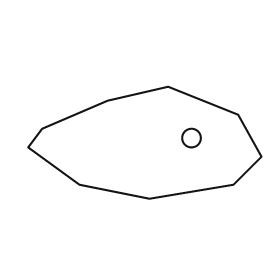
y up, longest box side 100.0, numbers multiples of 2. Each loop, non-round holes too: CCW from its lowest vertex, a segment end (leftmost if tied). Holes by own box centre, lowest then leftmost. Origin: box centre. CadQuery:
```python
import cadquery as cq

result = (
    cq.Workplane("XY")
    .moveTo(2.0, -24.0)
    .lineTo(38.0, -18.0)
    .lineTo(50.0, -6.0)
    .lineTo(40.0, 12.0)
    .lineTo(10.0, 24.0)
    .lineTo(-16.0, 18.0)
    .lineTo(-44.0, 6.0)
    .lineTo(-50.0, -2.0)
    .lineTo(-28.0, -18.0)
    .close()
    .moveTo(20.0, 2.0)
    .circle(4.0)
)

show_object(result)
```